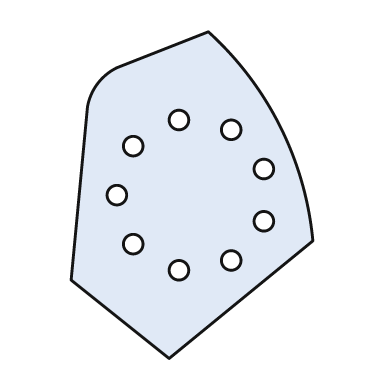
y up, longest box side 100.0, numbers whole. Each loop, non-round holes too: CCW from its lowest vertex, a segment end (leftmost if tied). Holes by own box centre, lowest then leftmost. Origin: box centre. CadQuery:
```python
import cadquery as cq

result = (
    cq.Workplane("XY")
    .moveTo(-7.0, -50.0)
    .lineTo(37.0, -14.0)
    .threePointArc((27.0, 21.0), (5.0, 50.0))
    .lineTo(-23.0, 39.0)
    .threePointArc((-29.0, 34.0), (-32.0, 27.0))
    .lineTo(-37.0, -26.0)
    .close()
    .moveTo(-4.0, -23.0)
    .circle(3.0)
    .moveTo(12.0, -20.0)
    .circle(3.0)
    .moveTo(-18.0, -15.0)
    .circle(3.0)
    .moveTo(22.0, -8.0)
    .circle(3.0)
    .moveTo(-23.0, 0.0)
    .circle(3.0)
    .moveTo(22.0, 8.0)
    .circle(3.0)
    .moveTo(-18.0, 15.0)
    .circle(3.0)
    .moveTo(12.0, 20.0)
    .circle(3.0)
    .moveTo(-4.0, 23.0)
    .circle(3.0)
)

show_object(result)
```